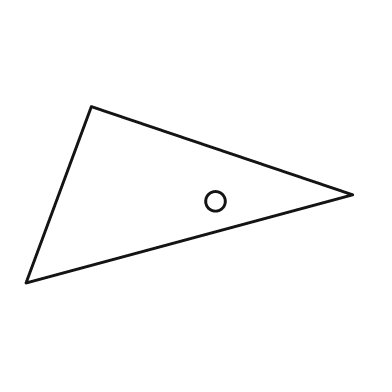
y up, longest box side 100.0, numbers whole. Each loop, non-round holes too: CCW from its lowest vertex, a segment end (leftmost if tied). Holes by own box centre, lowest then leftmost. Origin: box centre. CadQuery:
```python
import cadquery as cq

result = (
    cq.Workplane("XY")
    .moveTo(-50.0, -27.0)
    .lineTo(50.0, 0.0)
    .lineTo(-30.0, 27.0)
    .close()
    .moveTo(8.0, -2.0)
    .circle(3.0)
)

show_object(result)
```